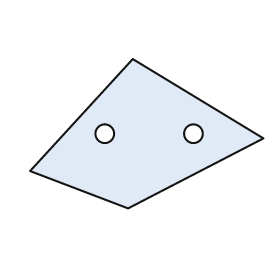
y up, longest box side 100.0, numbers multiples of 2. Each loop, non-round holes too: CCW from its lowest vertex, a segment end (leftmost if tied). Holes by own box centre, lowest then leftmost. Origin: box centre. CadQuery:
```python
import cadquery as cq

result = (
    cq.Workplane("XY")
    .moveTo(-8.0, -32.0)
    .lineTo(50.0, -2.0)
    .lineTo(-6.0, 32.0)
    .lineTo(-50.0, -16.0)
    .close()
    .moveTo(-18.0, 0.0)
    .circle(4.0)
    .moveTo(20.0, 0.0)
    .circle(4.0)
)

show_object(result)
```